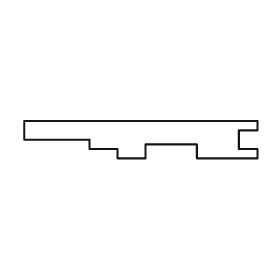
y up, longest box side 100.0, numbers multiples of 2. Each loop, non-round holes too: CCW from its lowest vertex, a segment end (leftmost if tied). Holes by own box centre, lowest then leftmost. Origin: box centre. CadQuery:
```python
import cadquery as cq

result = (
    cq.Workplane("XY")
    .moveTo(-10.0, -8.0)
    .lineTo(2.0, -8.0)
    .lineTo(2.0, -2.0)
    .lineTo(24.0, -2.0)
    .lineTo(24.0, -8.0)
    .lineTo(50.0, -8.0)
    .lineTo(50.0, -4.0)
    .lineTo(42.0, -4.0)
    .lineTo(42.0, 4.0)
    .lineTo(50.0, 4.0)
    .lineTo(50.0, 8.0)
    .lineTo(-50.0, 8.0)
    .lineTo(-50.0, 0.0)
    .lineTo(-22.0, 0.0)
    .lineTo(-22.0, -4.0)
    .lineTo(-10.0, -4.0)
    .close()
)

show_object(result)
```